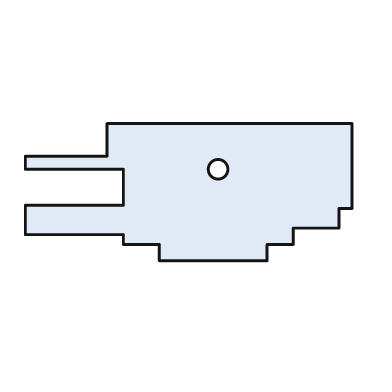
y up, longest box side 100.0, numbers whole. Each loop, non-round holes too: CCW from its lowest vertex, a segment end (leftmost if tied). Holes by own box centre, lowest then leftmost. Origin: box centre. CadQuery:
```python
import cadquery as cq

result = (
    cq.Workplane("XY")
    .moveTo(-9.0, -21.0)
    .lineTo(24.0, -21.0)
    .lineTo(24.0, -16.0)
    .lineTo(32.0, -16.0)
    .lineTo(32.0, -11.0)
    .lineTo(46.0, -11.0)
    .lineTo(46.0, -5.0)
    .lineTo(50.0, -5.0)
    .lineTo(50.0, 21.0)
    .lineTo(-25.0, 21.0)
    .lineTo(-25.0, 11.0)
    .lineTo(-50.0, 11.0)
    .lineTo(-50.0, 7.0)
    .lineTo(-20.0, 7.0)
    .lineTo(-20.0, -4.0)
    .lineTo(-50.0, -4.0)
    .lineTo(-50.0, -13.0)
    .lineTo(-20.0, -13.0)
    .lineTo(-20.0, -16.0)
    .lineTo(-9.0, -16.0)
    .close()
    .moveTo(9.0, 7.0)
    .circle(3.0)
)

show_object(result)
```